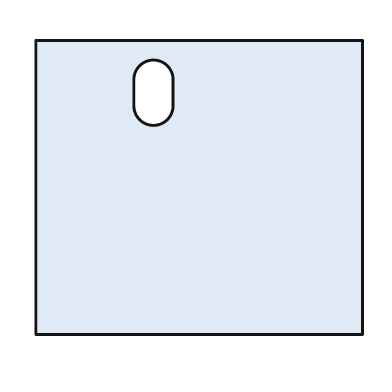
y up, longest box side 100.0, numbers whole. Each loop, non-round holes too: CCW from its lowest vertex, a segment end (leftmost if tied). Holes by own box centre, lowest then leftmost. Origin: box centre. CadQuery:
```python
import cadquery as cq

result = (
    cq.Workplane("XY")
    .moveTo(-50.0, -45.0)
    .lineTo(50.0, -45.0)
    .lineTo(50.0, 45.0)
    .lineTo(-50.0, 45.0)
    .close()
    .moveTo(-20.0, 25.0)
    .threePointArc((-14.0, 19.0), (-8.0, 25.0))
    .lineTo(-8.0, 33.0)
    .threePointArc((-14.0, 39.0), (-20.0, 33.0))
    .close()
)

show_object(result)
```